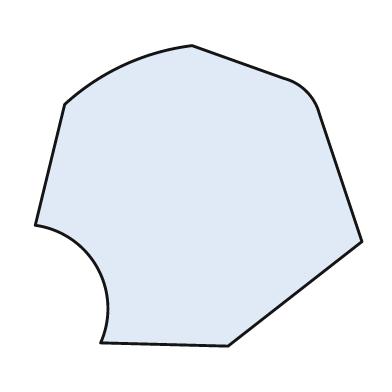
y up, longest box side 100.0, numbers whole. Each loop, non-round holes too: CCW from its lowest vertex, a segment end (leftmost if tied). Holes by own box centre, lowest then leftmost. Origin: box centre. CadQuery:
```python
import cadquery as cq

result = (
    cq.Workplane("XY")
    .moveTo(9.0, -46.0)
    .lineTo(50.0, -14.0)
    .lineTo(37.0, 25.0)
    .threePointArc((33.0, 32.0), (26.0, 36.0))
    .lineTo(-2.0, 46.0)
    .threePointArc((-23.0, 40.0), (-41.0, 28.0))
    .lineTo(-50.0, -9.0)
    .threePointArc((-31.0, -22.0), (-30.0, -45.0))
    .close()
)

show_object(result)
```